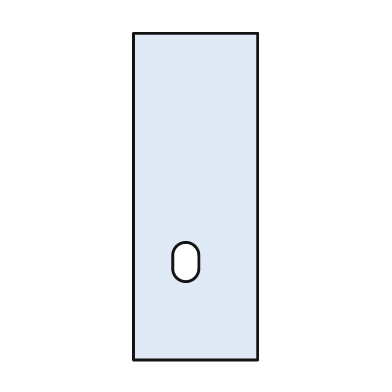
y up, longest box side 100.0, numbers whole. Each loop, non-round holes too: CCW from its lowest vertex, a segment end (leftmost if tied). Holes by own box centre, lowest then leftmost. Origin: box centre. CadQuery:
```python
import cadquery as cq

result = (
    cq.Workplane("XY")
    .moveTo(-19.0, -50.0)
    .lineTo(19.0, -50.0)
    .lineTo(19.0, 50.0)
    .lineTo(-19.0, 50.0)
    .close()
    .moveTo(-7.0, -22.0)
    .threePointArc((-3.0, -26.0), (1.0, -22.0))
    .lineTo(1.0, -18.0)
    .threePointArc((-3.0, -14.0), (-7.0, -18.0))
    .close()
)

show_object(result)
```